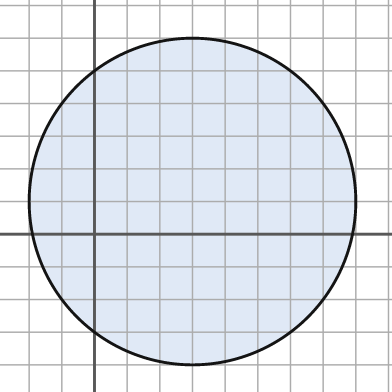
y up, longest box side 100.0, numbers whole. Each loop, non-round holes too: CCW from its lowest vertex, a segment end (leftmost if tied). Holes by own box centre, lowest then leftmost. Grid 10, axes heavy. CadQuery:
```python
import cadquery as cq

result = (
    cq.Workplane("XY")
    .moveTo(30.0, 10.0)
    .circle(50.0)
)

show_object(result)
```